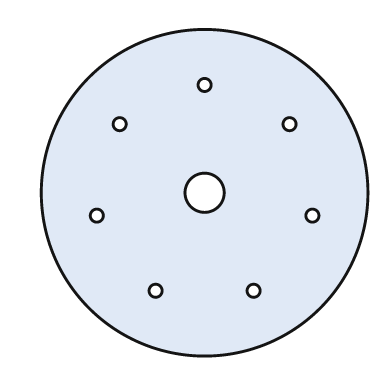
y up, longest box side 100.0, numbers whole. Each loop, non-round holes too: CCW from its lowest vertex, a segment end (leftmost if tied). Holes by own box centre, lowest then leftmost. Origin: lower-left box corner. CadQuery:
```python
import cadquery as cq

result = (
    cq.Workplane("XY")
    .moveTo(50.0, 50.0)
    .circle(50.0)
    .moveTo(35.0, 20.0)
    .circle(2.0)
    .moveTo(65.0, 20.0)
    .circle(2.0)
    .moveTo(17.0, 43.0)
    .circle(2.0)
    .moveTo(83.0, 43.0)
    .circle(2.0)
    .moveTo(50.0, 50.0)
    .circle(6.0)
    .moveTo(24.0, 71.0)
    .circle(2.0)
    .moveTo(76.0, 71.0)
    .circle(2.0)
    .moveTo(50.0, 83.0)
    .circle(2.0)
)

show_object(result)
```